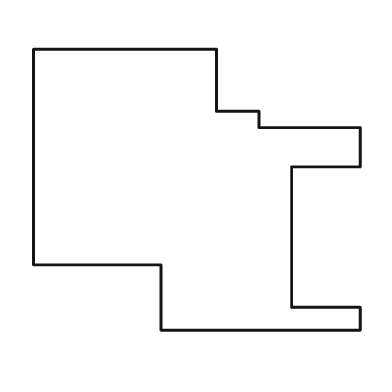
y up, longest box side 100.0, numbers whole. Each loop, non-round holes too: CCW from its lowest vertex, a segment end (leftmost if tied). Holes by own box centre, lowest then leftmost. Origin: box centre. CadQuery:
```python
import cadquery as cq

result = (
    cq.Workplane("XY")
    .moveTo(-11.0, -43.0)
    .lineTo(50.0, -43.0)
    .lineTo(50.0, -36.0)
    .lineTo(29.0, -36.0)
    .lineTo(29.0, 7.0)
    .lineTo(50.0, 7.0)
    .lineTo(50.0, 19.0)
    .lineTo(19.0, 19.0)
    .lineTo(19.0, 24.0)
    .lineTo(6.0, 24.0)
    .lineTo(6.0, 43.0)
    .lineTo(-50.0, 43.0)
    .lineTo(-50.0, -23.0)
    .lineTo(-11.0, -23.0)
    .close()
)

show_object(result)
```